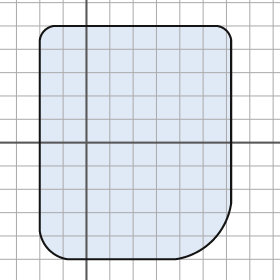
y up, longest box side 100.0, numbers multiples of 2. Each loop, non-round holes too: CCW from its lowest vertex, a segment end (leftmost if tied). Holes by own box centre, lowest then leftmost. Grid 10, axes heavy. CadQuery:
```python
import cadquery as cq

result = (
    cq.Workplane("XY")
    .moveTo(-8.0, -50.0)
    .lineTo(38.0, -50.0)
    .threePointArc((54.0, -42.0), (62.0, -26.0))
    .lineTo(62.0, 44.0)
    .threePointArc((60.0, 48.0), (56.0, 50.0))
    .lineTo(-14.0, 50.0)
    .threePointArc((-18.0, 48.0), (-20.0, 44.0))
    .lineTo(-20.0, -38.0)
    .threePointArc((-16.0, -46.0), (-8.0, -50.0))
    .close()
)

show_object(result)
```